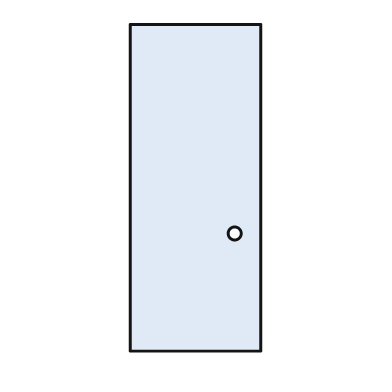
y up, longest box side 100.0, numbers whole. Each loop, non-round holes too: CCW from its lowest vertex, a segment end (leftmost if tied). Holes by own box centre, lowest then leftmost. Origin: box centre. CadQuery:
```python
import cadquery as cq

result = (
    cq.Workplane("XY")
    .moveTo(-20.0, -50.0)
    .lineTo(20.0, -50.0)
    .lineTo(20.0, 50.0)
    .lineTo(-20.0, 50.0)
    .close()
    .moveTo(12.0, -14.0)
    .circle(2.0)
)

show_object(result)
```